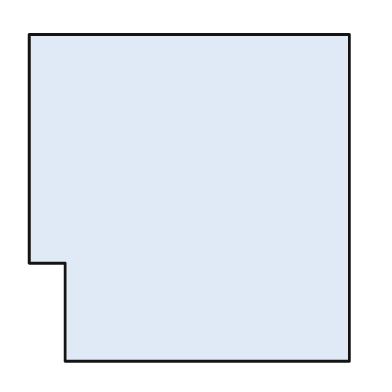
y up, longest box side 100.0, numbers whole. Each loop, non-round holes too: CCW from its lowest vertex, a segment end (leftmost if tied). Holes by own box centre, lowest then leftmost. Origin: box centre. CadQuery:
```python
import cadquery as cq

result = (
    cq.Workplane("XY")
    .moveTo(-38.0, -50.0)
    .lineTo(49.0, -50.0)
    .lineTo(49.0, 50.0)
    .lineTo(-49.0, 50.0)
    .lineTo(-49.0, -20.0)
    .lineTo(-38.0, -20.0)
    .close()
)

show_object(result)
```